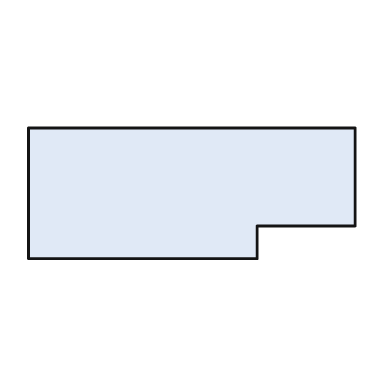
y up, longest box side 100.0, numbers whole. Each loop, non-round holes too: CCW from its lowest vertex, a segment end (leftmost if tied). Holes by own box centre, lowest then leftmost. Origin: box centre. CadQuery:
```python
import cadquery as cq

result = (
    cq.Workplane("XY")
    .moveTo(-50.0, -20.0)
    .lineTo(20.0, -20.0)
    .lineTo(20.0, -10.0)
    .lineTo(50.0, -10.0)
    .lineTo(50.0, 20.0)
    .lineTo(-50.0, 20.0)
    .close()
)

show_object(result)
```